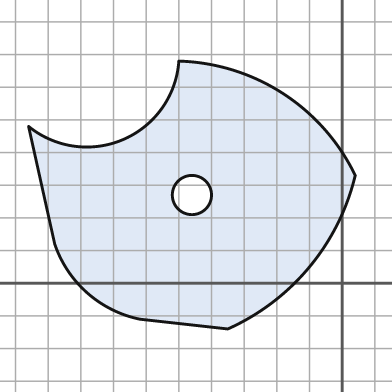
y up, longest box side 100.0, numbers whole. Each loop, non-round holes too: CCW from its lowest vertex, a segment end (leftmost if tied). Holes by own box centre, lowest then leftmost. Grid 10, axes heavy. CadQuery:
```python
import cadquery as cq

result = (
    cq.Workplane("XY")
    .moveTo(-35.0, -14.0)
    .threePointArc((-10.0, 5.0), (4.0, 33.0))
    .threePointArc((-18.0, 58.0), (-50.0, 68.0))
    .threePointArc((-67.0, 44.0), (-96.0, 48.0))
    .lineTo(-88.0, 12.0)
    .threePointArc((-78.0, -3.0), (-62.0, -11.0))
    .close()
    .moveTo(-46.0, 27.0)
    .circle(6.0)
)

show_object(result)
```